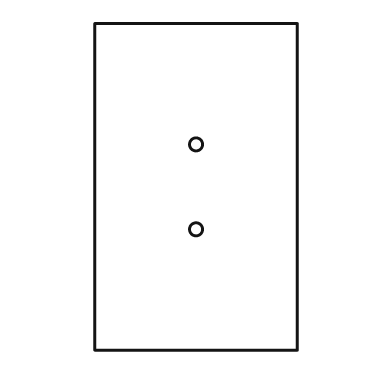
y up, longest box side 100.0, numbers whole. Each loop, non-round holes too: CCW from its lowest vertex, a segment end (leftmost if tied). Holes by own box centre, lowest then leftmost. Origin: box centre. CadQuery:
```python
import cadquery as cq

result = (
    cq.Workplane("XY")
    .moveTo(-31.0, -50.0)
    .lineTo(31.0, -50.0)
    .lineTo(31.0, 50.0)
    .lineTo(-31.0, 50.0)
    .close()
    .moveTo(0.0, -13.0)
    .circle(2.0)
    .moveTo(0.0, 13.0)
    .circle(2.0)
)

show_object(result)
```